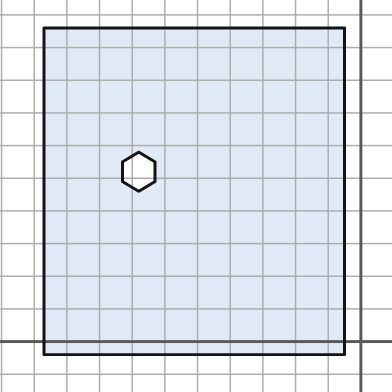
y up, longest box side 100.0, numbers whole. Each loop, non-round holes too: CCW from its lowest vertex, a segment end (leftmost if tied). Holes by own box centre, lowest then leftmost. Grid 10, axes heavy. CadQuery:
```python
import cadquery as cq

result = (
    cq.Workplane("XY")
    .moveTo(-97.0, -4.0)
    .lineTo(-5.0, -4.0)
    .lineTo(-5.0, 96.0)
    .lineTo(-97.0, 96.0)
    .close()
    .moveTo(-68.0, 46.0)
    .lineTo(-63.0, 49.0)
    .lineTo(-63.0, 55.0)
    .lineTo(-68.0, 58.0)
    .lineTo(-73.0, 55.0)
    .lineTo(-73.0, 49.0)
    .close()
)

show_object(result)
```